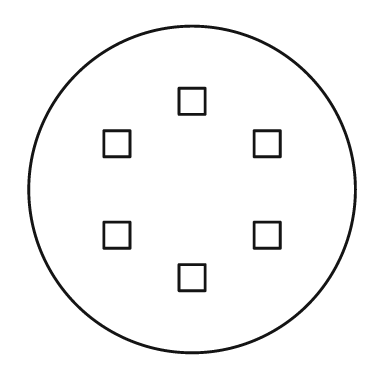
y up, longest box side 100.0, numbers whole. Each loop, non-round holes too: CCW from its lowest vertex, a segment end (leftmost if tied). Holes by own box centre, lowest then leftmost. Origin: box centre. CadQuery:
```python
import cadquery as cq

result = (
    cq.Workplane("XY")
    .moveTo(0.0, 0.0)
    .circle(50.0)
    .moveTo(-4.0, -31.0)
    .lineTo(4.0, -31.0)
    .lineTo(4.0, -23.0)
    .lineTo(-4.0, -23.0)
    .close()
    .moveTo(-27.0, -18.0)
    .lineTo(-19.0, -18.0)
    .lineTo(-19.0, -10.0)
    .lineTo(-27.0, -10.0)
    .close()
    .moveTo(19.0, -18.0)
    .lineTo(27.0, -18.0)
    .lineTo(27.0, -10.0)
    .lineTo(19.0, -10.0)
    .close()
    .moveTo(-27.0, 10.0)
    .lineTo(-19.0, 10.0)
    .lineTo(-19.0, 18.0)
    .lineTo(-27.0, 18.0)
    .close()
    .moveTo(19.0, 10.0)
    .lineTo(27.0, 10.0)
    .lineTo(27.0, 18.0)
    .lineTo(19.0, 18.0)
    .close()
    .moveTo(-4.0, 23.0)
    .lineTo(4.0, 23.0)
    .lineTo(4.0, 31.0)
    .lineTo(-4.0, 31.0)
    .close()
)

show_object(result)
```